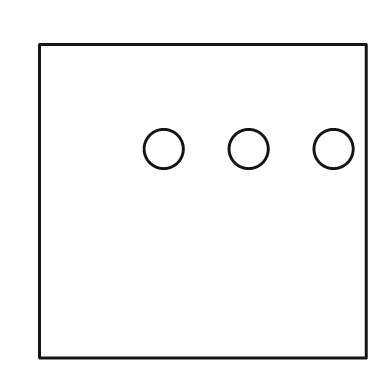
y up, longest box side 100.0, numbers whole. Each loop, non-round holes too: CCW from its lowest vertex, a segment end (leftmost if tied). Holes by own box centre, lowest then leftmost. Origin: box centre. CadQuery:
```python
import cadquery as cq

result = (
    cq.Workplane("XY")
    .moveTo(-50.0, -48.0)
    .lineTo(50.0, -48.0)
    .lineTo(50.0, 48.0)
    .lineTo(-50.0, 48.0)
    .close()
    .moveTo(-12.0, 16.0)
    .circle(6.0)
    .moveTo(14.0, 16.0)
    .circle(6.0)
    .moveTo(40.0, 16.0)
    .circle(6.0)
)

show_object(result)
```